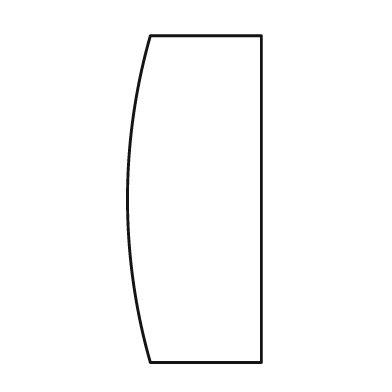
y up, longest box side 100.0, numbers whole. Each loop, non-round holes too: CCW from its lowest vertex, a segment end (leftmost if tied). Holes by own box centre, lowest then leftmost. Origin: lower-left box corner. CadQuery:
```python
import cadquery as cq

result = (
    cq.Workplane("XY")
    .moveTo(7.0, 0.0)
    .lineTo(41.0, 0.0)
    .lineTo(41.0, 100.0)
    .lineTo(7.0, 100.0)
    .threePointArc((0.0, 50.0), (7.0, 0.0))
    .close()
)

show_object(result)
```